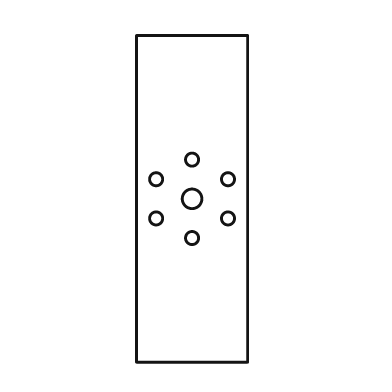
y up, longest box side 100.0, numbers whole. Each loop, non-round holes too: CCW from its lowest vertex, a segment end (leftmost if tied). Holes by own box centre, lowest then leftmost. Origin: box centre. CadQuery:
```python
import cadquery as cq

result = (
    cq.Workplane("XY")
    .moveTo(-17.0, -50.0)
    .lineTo(17.0, -50.0)
    .lineTo(17.0, 50.0)
    .lineTo(-17.0, 50.0)
    .close()
    .moveTo(0.0, -12.0)
    .circle(2.0)
    .moveTo(-11.0, -6.0)
    .circle(2.0)
    .moveTo(11.0, -6.0)
    .circle(2.0)
    .moveTo(0.0, 0.0)
    .circle(3.0)
    .moveTo(-11.0, 6.0)
    .circle(2.0)
    .moveTo(11.0, 6.0)
    .circle(2.0)
    .moveTo(0.0, 12.0)
    .circle(2.0)
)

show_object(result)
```